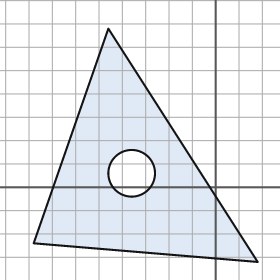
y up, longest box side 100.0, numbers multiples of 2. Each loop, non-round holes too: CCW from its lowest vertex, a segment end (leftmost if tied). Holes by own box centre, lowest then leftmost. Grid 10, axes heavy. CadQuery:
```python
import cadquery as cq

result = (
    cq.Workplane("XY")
    .moveTo(18.0, -32.0)
    .lineTo(-46.0, 68.0)
    .lineTo(-78.0, -24.0)
    .close()
    .moveTo(-36.0, 6.0)
    .circle(10.0)
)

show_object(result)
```